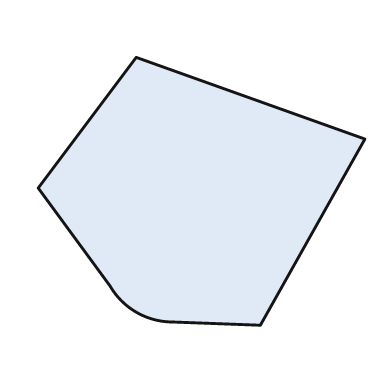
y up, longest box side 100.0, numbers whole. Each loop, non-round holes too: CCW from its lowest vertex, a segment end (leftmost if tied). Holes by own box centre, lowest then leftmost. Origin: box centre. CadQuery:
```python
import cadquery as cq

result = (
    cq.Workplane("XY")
    .moveTo(18.0, -41.0)
    .lineTo(50.0, 16.0)
    .lineTo(-20.0, 41.0)
    .lineTo(-50.0, 1.0)
    .lineTo(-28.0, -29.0)
    .threePointArc((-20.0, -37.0), (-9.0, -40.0))
    .close()
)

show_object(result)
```